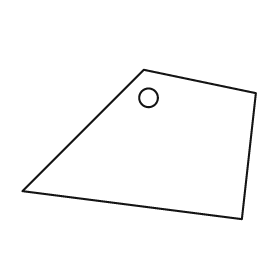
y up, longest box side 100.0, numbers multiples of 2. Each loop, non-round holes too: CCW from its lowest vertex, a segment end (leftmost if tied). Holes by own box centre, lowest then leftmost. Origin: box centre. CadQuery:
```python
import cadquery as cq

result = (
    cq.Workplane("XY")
    .moveTo(44.0, -32.0)
    .lineTo(50.0, 22.0)
    .lineTo(2.0, 32.0)
    .lineTo(-50.0, -20.0)
    .close()
    .moveTo(4.0, 20.0)
    .circle(4.0)
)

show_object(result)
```